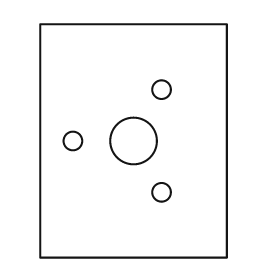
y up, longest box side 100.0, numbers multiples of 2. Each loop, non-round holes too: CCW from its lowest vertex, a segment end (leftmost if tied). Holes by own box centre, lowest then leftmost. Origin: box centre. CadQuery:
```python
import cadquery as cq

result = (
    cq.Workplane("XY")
    .moveTo(-40.0, -50.0)
    .lineTo(40.0, -50.0)
    .lineTo(40.0, 50.0)
    .lineTo(-40.0, 50.0)
    .close()
    .moveTo(12.0, -22.0)
    .circle(4.0)
    .moveTo(-26.0, 0.0)
    .circle(4.0)
    .moveTo(0.0, 0.0)
    .circle(10.0)
    .moveTo(12.0, 22.0)
    .circle(4.0)
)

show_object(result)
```